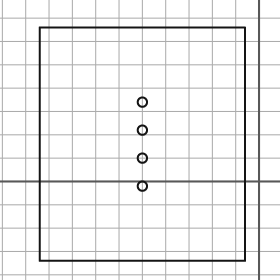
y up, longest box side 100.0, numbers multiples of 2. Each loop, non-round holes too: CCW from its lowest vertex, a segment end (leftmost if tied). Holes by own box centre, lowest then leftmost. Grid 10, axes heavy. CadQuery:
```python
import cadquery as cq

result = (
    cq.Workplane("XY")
    .moveTo(-94.0, -34.0)
    .lineTo(-6.0, -34.0)
    .lineTo(-6.0, 66.0)
    .lineTo(-94.0, 66.0)
    .close()
    .moveTo(-50.0, -2.0)
    .circle(2.0)
    .moveTo(-50.0, 10.0)
    .circle(2.0)
    .moveTo(-50.0, 22.0)
    .circle(2.0)
    .moveTo(-50.0, 34.0)
    .circle(2.0)
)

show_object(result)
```